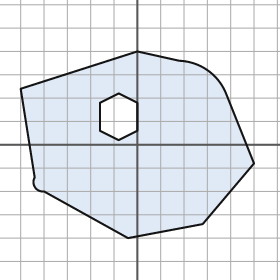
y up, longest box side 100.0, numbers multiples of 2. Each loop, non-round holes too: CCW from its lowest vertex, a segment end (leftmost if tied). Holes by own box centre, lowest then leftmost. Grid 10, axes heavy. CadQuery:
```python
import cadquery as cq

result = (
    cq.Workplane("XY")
    .moveTo(-4.0, -40.0)
    .lineTo(28.0, -34.0)
    .lineTo(50.0, -8.0)
    .lineTo(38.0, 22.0)
    .threePointArc((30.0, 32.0), (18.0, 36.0))
    .lineTo(0.0, 40.0)
    .lineTo(-50.0, 24.0)
    .lineTo(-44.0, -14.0)
    .threePointArc((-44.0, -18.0), (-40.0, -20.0))
    .close()
    .moveTo(-8.0, 2.0)
    .lineTo(0.0, 6.0)
    .lineTo(0.0, 18.0)
    .lineTo(-8.0, 22.0)
    .lineTo(-16.0, 18.0)
    .lineTo(-16.0, 6.0)
    .close()
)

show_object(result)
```